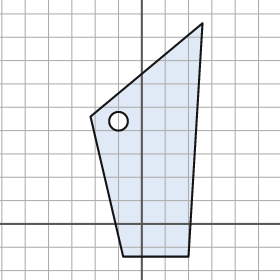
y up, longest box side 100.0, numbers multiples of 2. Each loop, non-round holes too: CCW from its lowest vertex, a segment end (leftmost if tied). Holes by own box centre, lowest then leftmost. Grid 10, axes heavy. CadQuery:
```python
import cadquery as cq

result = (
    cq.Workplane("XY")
    .moveTo(-8.0, -14.0)
    .lineTo(20.0, -14.0)
    .lineTo(26.0, 86.0)
    .lineTo(-22.0, 46.0)
    .close()
    .moveTo(-10.0, 44.0)
    .circle(4.0)
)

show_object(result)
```